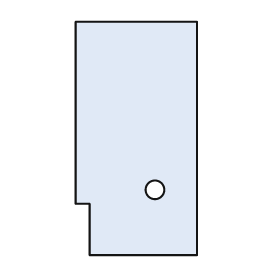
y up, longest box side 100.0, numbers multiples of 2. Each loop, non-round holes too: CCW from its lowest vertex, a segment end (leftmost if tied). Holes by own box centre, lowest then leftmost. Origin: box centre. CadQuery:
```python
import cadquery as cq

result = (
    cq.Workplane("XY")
    .moveTo(-20.0, -50.0)
    .lineTo(26.0, -50.0)
    .lineTo(26.0, 50.0)
    .lineTo(-26.0, 50.0)
    .lineTo(-26.0, -28.0)
    .lineTo(-20.0, -28.0)
    .close()
    .moveTo(8.0, -22.0)
    .circle(4.0)
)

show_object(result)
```